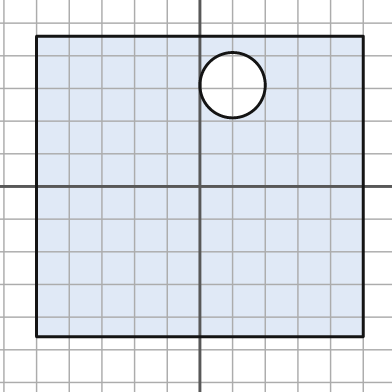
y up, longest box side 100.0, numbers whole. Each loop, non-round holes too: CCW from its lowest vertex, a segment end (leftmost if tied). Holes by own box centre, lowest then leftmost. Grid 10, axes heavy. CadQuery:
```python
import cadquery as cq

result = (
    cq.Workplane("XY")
    .moveTo(-50.0, -46.0)
    .lineTo(50.0, -46.0)
    .lineTo(50.0, 46.0)
    .lineTo(-50.0, 46.0)
    .close()
    .moveTo(10.0, 31.0)
    .circle(10.0)
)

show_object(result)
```